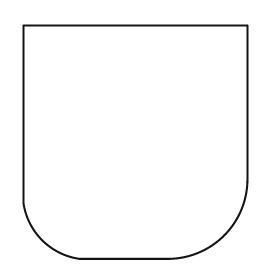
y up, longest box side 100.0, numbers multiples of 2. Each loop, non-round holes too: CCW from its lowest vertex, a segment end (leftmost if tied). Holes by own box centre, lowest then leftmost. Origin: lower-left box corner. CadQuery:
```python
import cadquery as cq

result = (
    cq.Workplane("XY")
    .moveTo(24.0, 0.0)
    .lineTo(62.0, 0.0)
    .threePointArc((86.0, 10.0), (96.0, 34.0))
    .lineTo(96.0, 100.0)
    .lineTo(0.0, 100.0)
    .lineTo(0.0, 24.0)
    .threePointArc((8.0, 8.0), (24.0, 0.0))
    .close()
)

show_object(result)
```